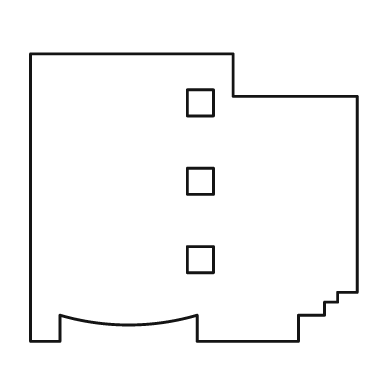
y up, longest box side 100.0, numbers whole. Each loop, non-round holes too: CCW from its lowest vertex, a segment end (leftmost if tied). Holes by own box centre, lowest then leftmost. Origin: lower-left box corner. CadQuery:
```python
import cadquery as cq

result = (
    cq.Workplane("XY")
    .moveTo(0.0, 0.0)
    .lineTo(9.0, 0.0)
    .lineTo(9.0, 8.0)
    .threePointArc((30.0, 5.0), (51.0, 8.0))
    .lineTo(51.0, 0.0)
    .lineTo(82.0, 0.0)
    .lineTo(82.0, 8.0)
    .lineTo(90.0, 8.0)
    .lineTo(90.0, 12.0)
    .lineTo(94.0, 12.0)
    .lineTo(94.0, 15.0)
    .lineTo(100.0, 15.0)
    .lineTo(100.0, 75.0)
    .lineTo(62.0, 75.0)
    .lineTo(62.0, 88.0)
    .lineTo(0.0, 88.0)
    .close()
    .moveTo(48.0, 21.0)
    .lineTo(56.0, 21.0)
    .lineTo(56.0, 29.0)
    .lineTo(48.0, 29.0)
    .close()
    .moveTo(48.0, 45.0)
    .lineTo(56.0, 45.0)
    .lineTo(56.0, 53.0)
    .lineTo(48.0, 53.0)
    .close()
    .moveTo(48.0, 69.0)
    .lineTo(56.0, 69.0)
    .lineTo(56.0, 77.0)
    .lineTo(48.0, 77.0)
    .close()
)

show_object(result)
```